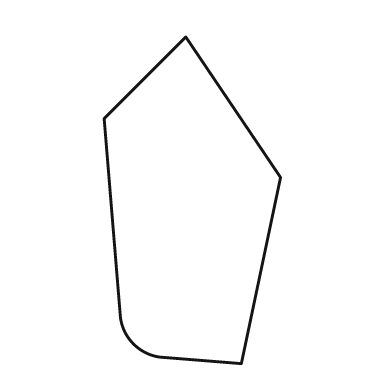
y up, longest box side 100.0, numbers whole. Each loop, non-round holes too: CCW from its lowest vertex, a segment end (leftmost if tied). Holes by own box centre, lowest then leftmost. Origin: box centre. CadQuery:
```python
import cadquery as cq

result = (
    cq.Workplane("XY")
    .moveTo(15.0, -50.0)
    .lineTo(27.0, 7.0)
    .lineTo(-2.0, 50.0)
    .lineTo(-27.0, 25.0)
    .lineTo(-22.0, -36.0)
    .threePointArc((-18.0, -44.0), (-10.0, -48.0))
    .close()
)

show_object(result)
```